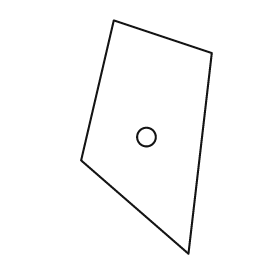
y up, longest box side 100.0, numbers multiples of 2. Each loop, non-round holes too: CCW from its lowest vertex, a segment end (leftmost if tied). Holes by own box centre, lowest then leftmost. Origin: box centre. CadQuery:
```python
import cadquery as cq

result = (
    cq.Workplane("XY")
    .moveTo(18.0, -50.0)
    .lineTo(28.0, 36.0)
    .lineTo(-14.0, 50.0)
    .lineTo(-28.0, -10.0)
    .close()
    .moveTo(0.0, 0.0)
    .circle(4.0)
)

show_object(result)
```